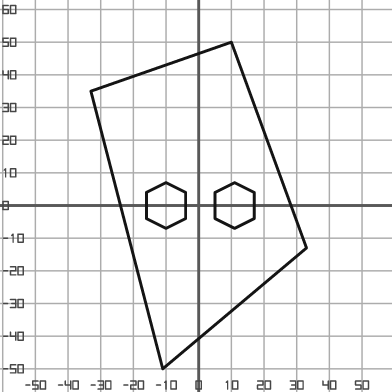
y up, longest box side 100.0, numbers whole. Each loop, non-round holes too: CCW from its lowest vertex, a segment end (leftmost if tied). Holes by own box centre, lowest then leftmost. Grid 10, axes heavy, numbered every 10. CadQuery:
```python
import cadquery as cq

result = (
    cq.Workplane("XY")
    .moveTo(-11.0, -50.0)
    .lineTo(33.0, -13.0)
    .lineTo(10.0, 50.0)
    .lineTo(-33.0, 35.0)
    .close()
    .moveTo(-10.0, -7.0)
    .lineTo(-4.0, -4.0)
    .lineTo(-4.0, 4.0)
    .lineTo(-10.0, 7.0)
    .lineTo(-16.0, 4.0)
    .lineTo(-16.0, -4.0)
    .close()
    .moveTo(11.0, -7.0)
    .lineTo(17.0, -4.0)
    .lineTo(17.0, 4.0)
    .lineTo(11.0, 7.0)
    .lineTo(5.0, 4.0)
    .lineTo(5.0, -4.0)
    .close()
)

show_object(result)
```